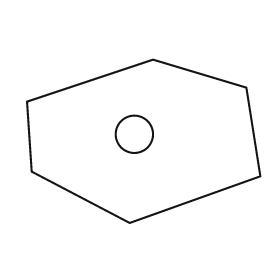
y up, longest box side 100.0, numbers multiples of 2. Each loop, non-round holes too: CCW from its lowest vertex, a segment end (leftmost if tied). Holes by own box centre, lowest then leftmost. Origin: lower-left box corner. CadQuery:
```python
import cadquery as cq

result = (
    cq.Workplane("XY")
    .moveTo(44.0, 0.0)
    .lineTo(100.0, 20.0)
    .lineTo(94.0, 58.0)
    .lineTo(54.0, 70.0)
    .lineTo(0.0, 52.0)
    .lineTo(2.0, 22.0)
    .close()
    .moveTo(46.0, 38.0)
    .circle(8.0)
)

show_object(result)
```